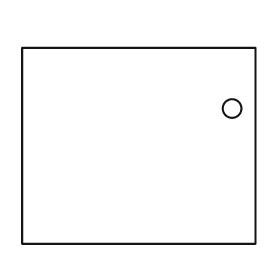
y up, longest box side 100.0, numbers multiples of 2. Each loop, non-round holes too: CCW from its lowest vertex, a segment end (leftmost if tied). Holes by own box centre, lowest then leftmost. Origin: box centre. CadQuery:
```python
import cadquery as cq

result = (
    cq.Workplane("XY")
    .moveTo(-50.0, -42.0)
    .lineTo(50.0, -42.0)
    .lineTo(50.0, 42.0)
    .lineTo(-50.0, 42.0)
    .close()
    .moveTo(40.0, 16.0)
    .circle(4.0)
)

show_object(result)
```